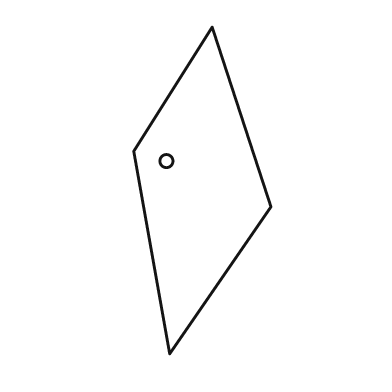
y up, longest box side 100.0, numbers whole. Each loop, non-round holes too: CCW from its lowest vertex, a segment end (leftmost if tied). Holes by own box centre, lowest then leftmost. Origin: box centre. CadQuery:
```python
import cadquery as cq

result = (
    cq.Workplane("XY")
    .moveTo(-10.0, -50.0)
    .lineTo(21.0, -5.0)
    .lineTo(3.0, 50.0)
    .lineTo(-21.0, 12.0)
    .close()
    .moveTo(-11.0, 9.0)
    .circle(2.0)
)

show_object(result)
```